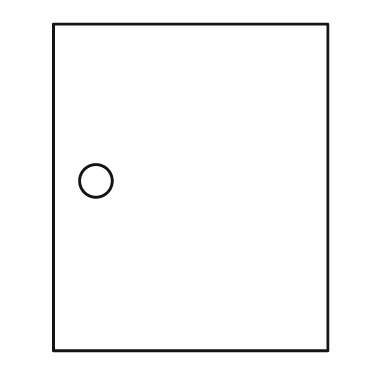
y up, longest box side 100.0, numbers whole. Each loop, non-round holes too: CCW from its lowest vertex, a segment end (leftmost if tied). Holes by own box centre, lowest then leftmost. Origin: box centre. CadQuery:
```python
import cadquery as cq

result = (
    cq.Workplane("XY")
    .moveTo(-42.0, -50.0)
    .lineTo(42.0, -50.0)
    .lineTo(42.0, 50.0)
    .lineTo(-42.0, 50.0)
    .close()
    .moveTo(-29.0, 2.0)
    .circle(5.0)
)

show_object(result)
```